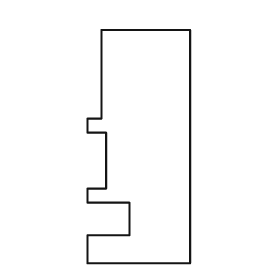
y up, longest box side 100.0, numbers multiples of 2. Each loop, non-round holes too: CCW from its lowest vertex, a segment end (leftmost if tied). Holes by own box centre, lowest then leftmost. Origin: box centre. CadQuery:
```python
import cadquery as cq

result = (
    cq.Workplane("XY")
    .moveTo(-22.0, -50.0)
    .lineTo(22.0, -50.0)
    .lineTo(22.0, 50.0)
    .lineTo(-16.0, 50.0)
    .lineTo(-16.0, 12.0)
    .lineTo(-22.0, 12.0)
    .lineTo(-22.0, 6.0)
    .lineTo(-14.0, 6.0)
    .lineTo(-14.0, -18.0)
    .lineTo(-22.0, -18.0)
    .lineTo(-22.0, -24.0)
    .lineTo(-4.0, -24.0)
    .lineTo(-4.0, -38.0)
    .lineTo(-22.0, -38.0)
    .close()
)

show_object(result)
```